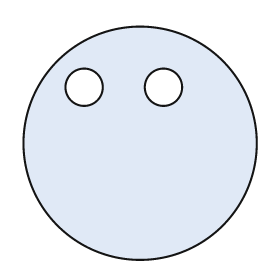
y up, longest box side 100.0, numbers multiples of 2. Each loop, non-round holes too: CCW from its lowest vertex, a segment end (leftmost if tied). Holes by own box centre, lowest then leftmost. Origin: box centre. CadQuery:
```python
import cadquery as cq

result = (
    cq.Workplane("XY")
    .moveTo(0.0, 0.0)
    .circle(50.0)
    .moveTo(-24.0, 24.0)
    .circle(8.0)
    .moveTo(10.0, 24.0)
    .circle(8.0)
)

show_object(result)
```